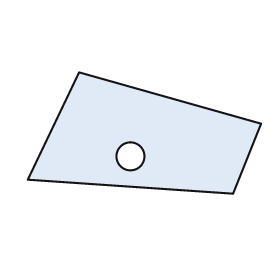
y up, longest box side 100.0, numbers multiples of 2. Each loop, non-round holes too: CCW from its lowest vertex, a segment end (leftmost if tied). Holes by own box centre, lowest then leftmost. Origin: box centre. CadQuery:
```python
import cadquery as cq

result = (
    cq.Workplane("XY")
    .moveTo(38.0, -26.0)
    .lineTo(50.0, 4.0)
    .lineTo(-28.0, 26.0)
    .lineTo(-50.0, -20.0)
    .close()
    .moveTo(-6.0, -10.0)
    .circle(6.0)
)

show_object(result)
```